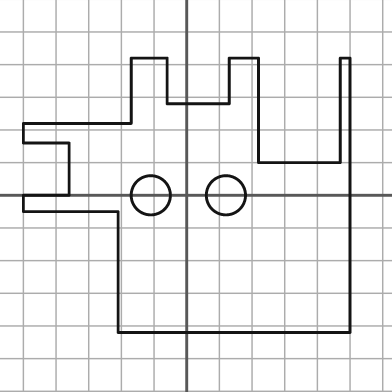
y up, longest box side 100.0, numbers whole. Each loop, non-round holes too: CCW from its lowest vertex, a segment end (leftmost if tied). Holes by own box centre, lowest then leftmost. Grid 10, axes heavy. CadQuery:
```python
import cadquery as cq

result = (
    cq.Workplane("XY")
    .moveTo(-21.0, -42.0)
    .lineTo(50.0, -42.0)
    .lineTo(50.0, 42.0)
    .lineTo(47.0, 42.0)
    .lineTo(47.0, 10.0)
    .lineTo(22.0, 10.0)
    .lineTo(22.0, 42.0)
    .lineTo(13.0, 42.0)
    .lineTo(13.0, 28.0)
    .lineTo(-6.0, 28.0)
    .lineTo(-6.0, 42.0)
    .lineTo(-17.0, 42.0)
    .lineTo(-17.0, 22.0)
    .lineTo(-50.0, 22.0)
    .lineTo(-50.0, 16.0)
    .lineTo(-36.0, 16.0)
    .lineTo(-36.0, 0.0)
    .lineTo(-50.0, 0.0)
    .lineTo(-50.0, -5.0)
    .lineTo(-21.0, -5.0)
    .close()
    .moveTo(-11.0, 0.0)
    .circle(6.0)
    .moveTo(12.0, 0.0)
    .circle(6.0)
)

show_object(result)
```